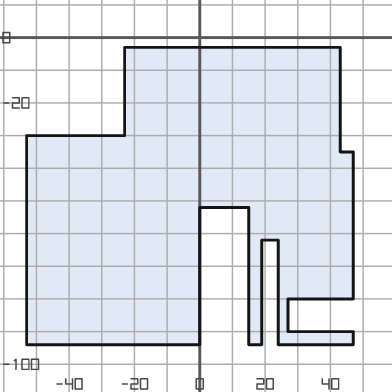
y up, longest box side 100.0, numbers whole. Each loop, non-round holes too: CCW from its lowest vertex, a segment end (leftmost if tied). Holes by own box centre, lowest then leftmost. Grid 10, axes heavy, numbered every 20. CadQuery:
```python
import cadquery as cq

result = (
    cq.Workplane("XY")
    .moveTo(-53.0, -94.0)
    .lineTo(0.0, -94.0)
    .lineTo(0.0, -52.0)
    .lineTo(15.0, -52.0)
    .lineTo(15.0, -94.0)
    .lineTo(19.0, -94.0)
    .lineTo(19.0, -62.0)
    .lineTo(24.0, -62.0)
    .lineTo(24.0, -94.0)
    .lineTo(47.0, -94.0)
    .lineTo(47.0, -90.0)
    .lineTo(27.0, -90.0)
    .lineTo(27.0, -80.0)
    .lineTo(47.0, -80.0)
    .lineTo(47.0, -35.0)
    .lineTo(43.0, -35.0)
    .lineTo(43.0, -3.0)
    .lineTo(-23.0, -3.0)
    .lineTo(-23.0, -30.0)
    .lineTo(-53.0, -30.0)
    .close()
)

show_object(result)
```